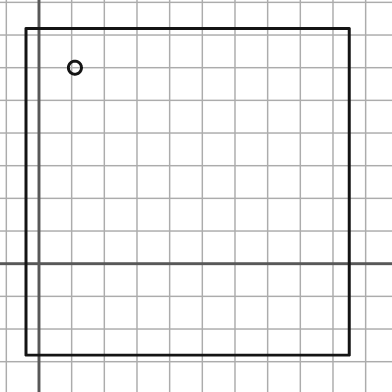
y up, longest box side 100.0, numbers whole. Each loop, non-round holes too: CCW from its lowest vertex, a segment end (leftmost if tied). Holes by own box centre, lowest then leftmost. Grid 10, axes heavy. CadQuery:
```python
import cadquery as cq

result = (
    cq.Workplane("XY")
    .moveTo(-4.0, -28.0)
    .lineTo(95.0, -28.0)
    .lineTo(95.0, 72.0)
    .lineTo(-4.0, 72.0)
    .close()
    .moveTo(11.0, 60.0)
    .circle(2.0)
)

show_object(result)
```